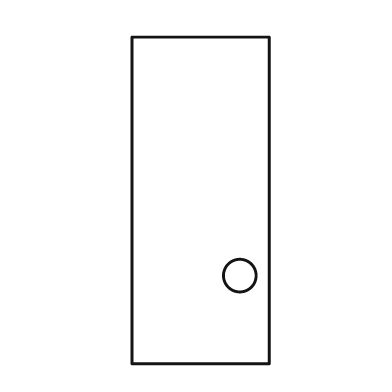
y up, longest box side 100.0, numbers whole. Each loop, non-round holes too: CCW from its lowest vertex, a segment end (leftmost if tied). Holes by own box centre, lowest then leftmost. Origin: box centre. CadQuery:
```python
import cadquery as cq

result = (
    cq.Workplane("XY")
    .moveTo(-21.0, -50.0)
    .lineTo(21.0, -50.0)
    .lineTo(21.0, 50.0)
    .lineTo(-21.0, 50.0)
    .close()
    .moveTo(12.0, -23.0)
    .circle(5.0)
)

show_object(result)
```